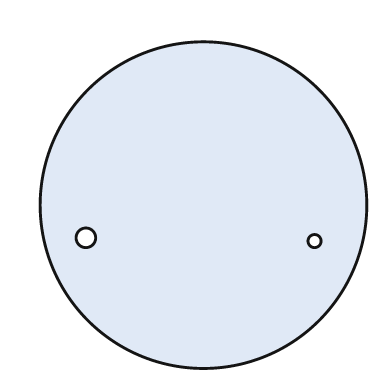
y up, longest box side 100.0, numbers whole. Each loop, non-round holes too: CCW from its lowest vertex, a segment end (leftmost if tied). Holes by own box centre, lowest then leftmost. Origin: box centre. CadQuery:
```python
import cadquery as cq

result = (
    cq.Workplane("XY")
    .moveTo(0.0, 0.0)
    .circle(50.0)
    .moveTo(34.0, -11.0)
    .circle(2.0)
    .moveTo(-36.0, -10.0)
    .circle(3.0)
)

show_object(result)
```